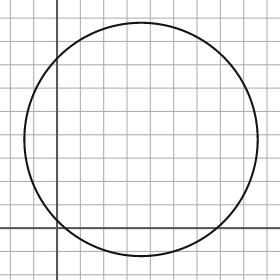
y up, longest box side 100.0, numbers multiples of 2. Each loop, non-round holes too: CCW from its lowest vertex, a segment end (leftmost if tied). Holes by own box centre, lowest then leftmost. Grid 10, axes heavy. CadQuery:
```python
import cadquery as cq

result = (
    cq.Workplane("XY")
    .moveTo(36.0, 38.0)
    .circle(50.0)
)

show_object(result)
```